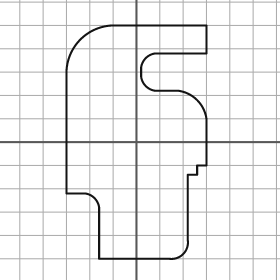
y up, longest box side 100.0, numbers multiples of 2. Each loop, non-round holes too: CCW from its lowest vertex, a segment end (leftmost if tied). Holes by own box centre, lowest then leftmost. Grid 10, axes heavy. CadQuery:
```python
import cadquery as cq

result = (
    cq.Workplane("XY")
    .moveTo(-16.0, -50.0)
    .lineTo(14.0, -50.0)
    .threePointArc((20.0, -48.0), (22.0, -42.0))
    .lineTo(22.0, -14.0)
    .lineTo(26.0, -14.0)
    .lineTo(26.0, -10.0)
    .lineTo(30.0, -10.0)
    .lineTo(30.0, 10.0)
    .threePointArc((26.0, 18.0), (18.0, 22.0))
    .lineTo(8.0, 22.0)
    .threePointArc((4.0, 24.0), (2.0, 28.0))
    .lineTo(2.0, 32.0)
    .threePointArc((4.0, 36.0), (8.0, 38.0))
    .lineTo(30.0, 38.0)
    .lineTo(30.0, 50.0)
    .lineTo(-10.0, 50.0)
    .threePointArc((-24.0, 44.0), (-30.0, 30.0))
    .lineTo(-30.0, -22.0)
    .lineTo(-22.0, -22.0)
    .threePointArc((-18.0, -24.0), (-16.0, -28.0))
    .close()
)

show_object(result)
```